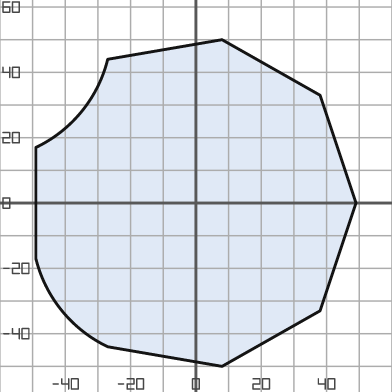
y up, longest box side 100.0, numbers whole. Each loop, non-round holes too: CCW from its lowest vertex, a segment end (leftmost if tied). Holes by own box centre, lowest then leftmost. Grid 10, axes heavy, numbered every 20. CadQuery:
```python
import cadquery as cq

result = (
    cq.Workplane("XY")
    .moveTo(8.0, -50.0)
    .lineTo(38.0, -33.0)
    .lineTo(49.0, 0.0)
    .lineTo(38.0, 33.0)
    .lineTo(8.0, 50.0)
    .lineTo(-27.0, 44.0)
    .threePointArc((-35.0, 28.0), (-49.0, 17.0))
    .lineTo(-49.0, -17.0)
    .threePointArc((-41.0, -33.0), (-27.0, -44.0))
    .close()
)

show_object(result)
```